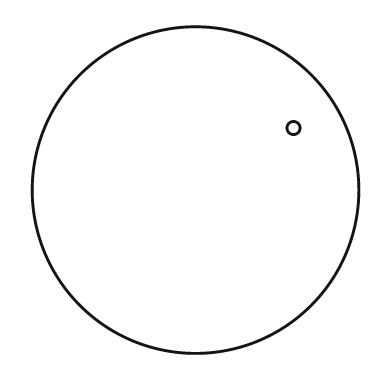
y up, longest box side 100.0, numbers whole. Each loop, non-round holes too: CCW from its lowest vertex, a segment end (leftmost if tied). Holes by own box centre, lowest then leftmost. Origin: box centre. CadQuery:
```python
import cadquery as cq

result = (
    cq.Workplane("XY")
    .moveTo(0.0, 0.0)
    .circle(50.0)
    .moveTo(30.0, 19.0)
    .circle(2.0)
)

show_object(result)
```